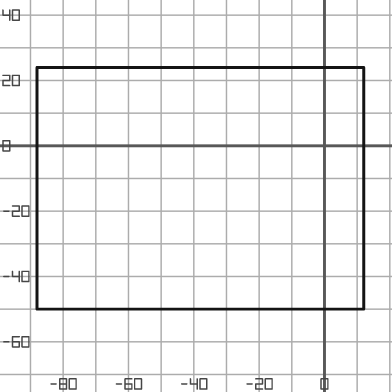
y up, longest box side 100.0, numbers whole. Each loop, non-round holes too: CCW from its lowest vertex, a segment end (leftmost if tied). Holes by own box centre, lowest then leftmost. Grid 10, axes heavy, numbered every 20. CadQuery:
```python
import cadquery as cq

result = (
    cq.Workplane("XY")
    .moveTo(-88.0, -50.0)
    .lineTo(12.0, -50.0)
    .lineTo(12.0, 24.0)
    .lineTo(-88.0, 24.0)
    .close()
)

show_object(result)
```